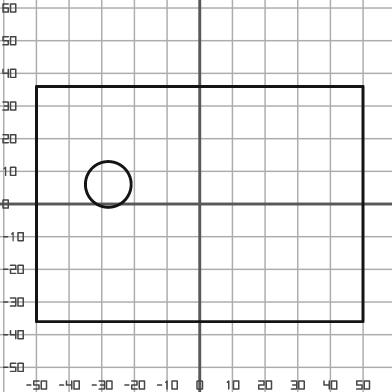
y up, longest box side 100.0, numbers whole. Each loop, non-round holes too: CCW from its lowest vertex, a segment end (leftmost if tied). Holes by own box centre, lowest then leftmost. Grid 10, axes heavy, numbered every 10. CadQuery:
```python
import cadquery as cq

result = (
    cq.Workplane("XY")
    .moveTo(-50.0, -36.0)
    .lineTo(50.0, -36.0)
    .lineTo(50.0, 36.0)
    .lineTo(-50.0, 36.0)
    .close()
    .moveTo(-28.0, 6.0)
    .circle(7.0)
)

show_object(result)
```